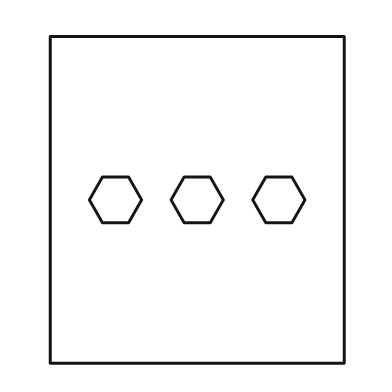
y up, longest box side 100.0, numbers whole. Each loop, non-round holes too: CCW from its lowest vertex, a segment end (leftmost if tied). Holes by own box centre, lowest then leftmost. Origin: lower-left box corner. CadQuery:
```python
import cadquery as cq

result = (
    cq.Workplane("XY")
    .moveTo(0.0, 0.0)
    .lineTo(90.0, 0.0)
    .lineTo(90.0, 100.0)
    .lineTo(0.0, 100.0)
    .close()
    .moveTo(16.0, 43.0)
    .lineTo(24.0, 43.0)
    .lineTo(28.0, 50.0)
    .lineTo(24.0, 57.0)
    .lineTo(16.0, 57.0)
    .lineTo(12.0, 50.0)
    .close()
    .moveTo(41.0, 43.0)
    .lineTo(49.0, 43.0)
    .lineTo(53.0, 50.0)
    .lineTo(49.0, 57.0)
    .lineTo(41.0, 57.0)
    .lineTo(37.0, 50.0)
    .close()
    .moveTo(66.0, 43.0)
    .lineTo(74.0, 43.0)
    .lineTo(78.0, 50.0)
    .lineTo(74.0, 57.0)
    .lineTo(66.0, 57.0)
    .lineTo(62.0, 50.0)
    .close()
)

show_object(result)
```